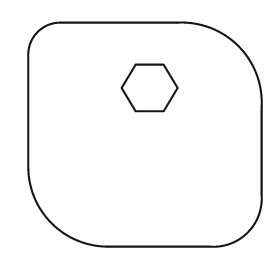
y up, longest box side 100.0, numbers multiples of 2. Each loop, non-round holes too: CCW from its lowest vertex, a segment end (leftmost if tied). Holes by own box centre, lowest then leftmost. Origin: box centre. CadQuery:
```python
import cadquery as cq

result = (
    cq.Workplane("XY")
    .moveTo(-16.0, -48.0)
    .lineTo(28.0, -48.0)
    .threePointArc((44.0, -42.0), (50.0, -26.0))
    .lineTo(50.0, 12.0)
    .threePointArc((40.0, 38.0), (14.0, 48.0))
    .lineTo(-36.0, 48.0)
    .threePointArc((-46.0, 44.0), (-50.0, 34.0))
    .lineTo(-50.0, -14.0)
    .threePointArc((-40.0, -38.0), (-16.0, -48.0))
    .close()
    .moveTo(-4.0, 10.0)
    .lineTo(8.0, 10.0)
    .lineTo(14.0, 20.0)
    .lineTo(8.0, 30.0)
    .lineTo(-4.0, 30.0)
    .lineTo(-10.0, 20.0)
    .close()
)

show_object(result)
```